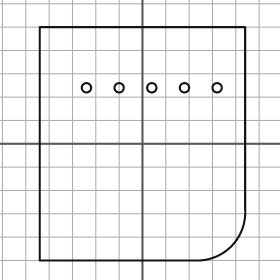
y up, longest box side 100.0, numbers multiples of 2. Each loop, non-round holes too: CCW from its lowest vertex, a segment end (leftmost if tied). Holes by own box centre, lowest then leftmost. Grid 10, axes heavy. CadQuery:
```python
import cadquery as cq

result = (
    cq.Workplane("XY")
    .moveTo(-44.0, -50.0)
    .lineTo(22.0, -50.0)
    .threePointArc((38.0, -44.0), (44.0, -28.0))
    .lineTo(44.0, 50.0)
    .lineTo(-44.0, 50.0)
    .close()
    .moveTo(-24.0, 24.0)
    .circle(2.0)
    .moveTo(-10.0, 24.0)
    .circle(2.0)
    .moveTo(4.0, 24.0)
    .circle(2.0)
    .moveTo(18.0, 24.0)
    .circle(2.0)
    .moveTo(32.0, 24.0)
    .circle(2.0)
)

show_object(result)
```